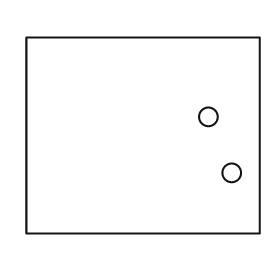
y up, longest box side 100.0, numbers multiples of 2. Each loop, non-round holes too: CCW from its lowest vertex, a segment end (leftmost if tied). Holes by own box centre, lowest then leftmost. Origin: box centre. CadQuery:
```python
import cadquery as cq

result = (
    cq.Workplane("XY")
    .moveTo(-50.0, -42.0)
    .lineTo(50.0, -42.0)
    .lineTo(50.0, 42.0)
    .lineTo(-50.0, 42.0)
    .close()
    .moveTo(38.0, -16.0)
    .circle(4.0)
    .moveTo(28.0, 8.0)
    .circle(4.0)
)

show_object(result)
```